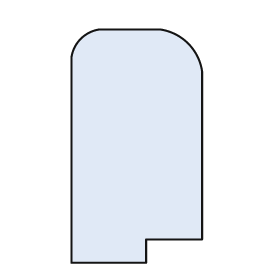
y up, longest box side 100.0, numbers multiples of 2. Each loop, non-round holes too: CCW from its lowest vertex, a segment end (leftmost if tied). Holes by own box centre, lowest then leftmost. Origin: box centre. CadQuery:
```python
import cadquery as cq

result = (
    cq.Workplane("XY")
    .moveTo(-28.0, -50.0)
    .lineTo(4.0, -50.0)
    .lineTo(4.0, -40.0)
    .lineTo(28.0, -40.0)
    .lineTo(28.0, 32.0)
    .threePointArc((22.0, 44.0), (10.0, 50.0))
    .lineTo(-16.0, 50.0)
    .threePointArc((-24.0, 46.0), (-28.0, 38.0))
    .close()
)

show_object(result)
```